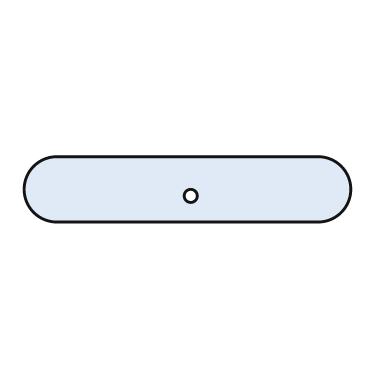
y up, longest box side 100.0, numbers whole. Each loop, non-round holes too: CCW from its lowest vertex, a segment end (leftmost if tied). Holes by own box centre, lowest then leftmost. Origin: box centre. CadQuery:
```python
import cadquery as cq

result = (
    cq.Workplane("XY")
    .moveTo(-40.0, -10.0)
    .lineTo(40.0, -10.0)
    .threePointArc((50.0, 0.0), (40.0, 10.0))
    .lineTo(-40.0, 10.0)
    .threePointArc((-50.0, 0.0), (-40.0, -10.0))
    .close()
    .moveTo(1.0, -2.0)
    .circle(2.0)
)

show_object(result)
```